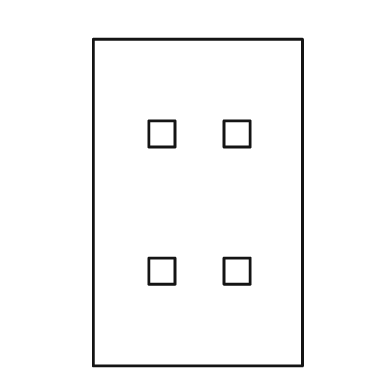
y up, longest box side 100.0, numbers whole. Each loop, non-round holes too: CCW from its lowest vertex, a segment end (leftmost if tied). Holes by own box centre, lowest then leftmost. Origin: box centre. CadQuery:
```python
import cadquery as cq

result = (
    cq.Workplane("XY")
    .moveTo(-32.0, -50.0)
    .lineTo(32.0, -50.0)
    .lineTo(32.0, 50.0)
    .lineTo(-32.0, 50.0)
    .close()
    .moveTo(-15.0, -25.0)
    .lineTo(-7.0, -25.0)
    .lineTo(-7.0, -17.0)
    .lineTo(-15.0, -17.0)
    .close()
    .moveTo(8.0, -25.0)
    .lineTo(16.0, -25.0)
    .lineTo(16.0, -17.0)
    .lineTo(8.0, -17.0)
    .close()
    .moveTo(-15.0, 17.0)
    .lineTo(-7.0, 17.0)
    .lineTo(-7.0, 25.0)
    .lineTo(-15.0, 25.0)
    .close()
    .moveTo(8.0, 17.0)
    .lineTo(16.0, 17.0)
    .lineTo(16.0, 25.0)
    .lineTo(8.0, 25.0)
    .close()
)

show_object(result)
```